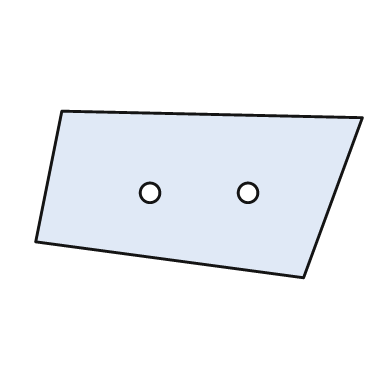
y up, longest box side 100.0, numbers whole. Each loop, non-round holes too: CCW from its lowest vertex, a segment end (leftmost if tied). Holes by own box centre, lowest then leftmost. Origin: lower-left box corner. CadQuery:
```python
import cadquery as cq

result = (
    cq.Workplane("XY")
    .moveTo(82.0, 0.0)
    .lineTo(100.0, 49.0)
    .lineTo(8.0, 51.0)
    .lineTo(0.0, 11.0)
    .close()
    .moveTo(35.0, 26.0)
    .circle(3.0)
    .moveTo(65.0, 26.0)
    .circle(3.0)
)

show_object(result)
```